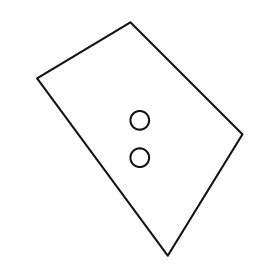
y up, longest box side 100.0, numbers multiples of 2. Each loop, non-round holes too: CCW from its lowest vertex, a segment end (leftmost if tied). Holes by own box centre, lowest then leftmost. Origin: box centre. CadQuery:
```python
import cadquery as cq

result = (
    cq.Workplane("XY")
    .moveTo(12.0, -50.0)
    .lineTo(44.0, 2.0)
    .lineTo(-4.0, 50.0)
    .lineTo(-44.0, 26.0)
    .close()
    .moveTo(0.0, -8.0)
    .circle(4.0)
    .moveTo(0.0, 8.0)
    .circle(4.0)
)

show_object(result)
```